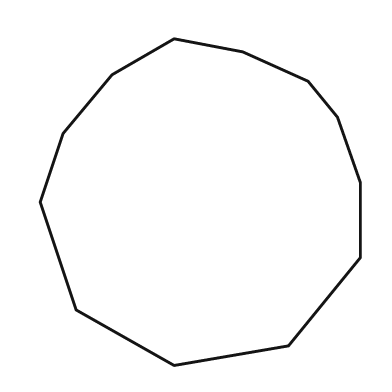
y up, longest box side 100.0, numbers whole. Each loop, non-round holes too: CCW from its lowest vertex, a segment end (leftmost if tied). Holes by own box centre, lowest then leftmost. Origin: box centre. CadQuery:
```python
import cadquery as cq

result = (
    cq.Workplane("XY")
    .moveTo(-8.0, -50.0)
    .lineTo(27.0, -44.0)
    .lineTo(49.0, -17.0)
    .lineTo(49.0, 6.0)
    .lineTo(42.0, 26.0)
    .lineTo(33.0, 37.0)
    .lineTo(13.0, 46.0)
    .lineTo(-8.0, 50.0)
    .lineTo(-27.0, 39.0)
    .lineTo(-42.0, 21.0)
    .lineTo(-49.0, 0.0)
    .lineTo(-38.0, -33.0)
    .close()
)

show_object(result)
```